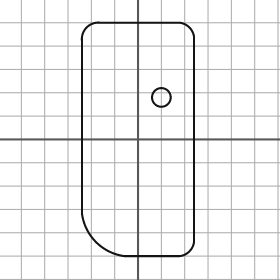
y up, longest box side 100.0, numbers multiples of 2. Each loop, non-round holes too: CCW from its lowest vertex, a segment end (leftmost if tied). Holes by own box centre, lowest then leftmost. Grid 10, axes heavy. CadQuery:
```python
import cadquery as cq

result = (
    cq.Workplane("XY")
    .moveTo(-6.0, -50.0)
    .lineTo(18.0, -50.0)
    .threePointArc((22.0, -48.0), (24.0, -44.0))
    .lineTo(24.0, 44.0)
    .threePointArc((22.0, 48.0), (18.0, 50.0))
    .lineTo(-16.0, 50.0)
    .threePointArc((-22.0, 48.0), (-24.0, 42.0))
    .lineTo(-24.0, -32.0)
    .threePointArc((-18.0, -44.0), (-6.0, -50.0))
    .close()
    .moveTo(10.0, 18.0)
    .circle(4.0)
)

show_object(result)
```